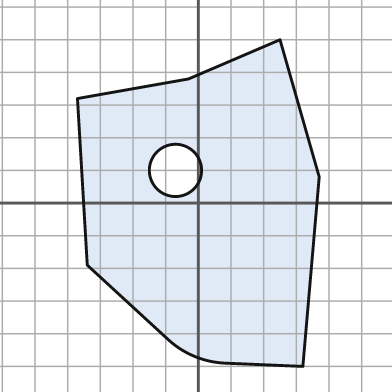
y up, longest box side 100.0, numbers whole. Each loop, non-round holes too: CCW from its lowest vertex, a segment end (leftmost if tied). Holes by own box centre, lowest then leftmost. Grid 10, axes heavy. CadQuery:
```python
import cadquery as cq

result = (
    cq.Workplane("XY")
    .moveTo(32.0, -50.0)
    .lineTo(37.0, 8.0)
    .lineTo(25.0, 50.0)
    .lineTo(-3.0, 38.0)
    .lineTo(-37.0, 32.0)
    .lineTo(-34.0, -19.0)
    .lineTo(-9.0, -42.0)
    .threePointArc((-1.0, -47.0), (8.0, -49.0))
    .close()
    .moveTo(-7.0, 10.0)
    .circle(8.0)
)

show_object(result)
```